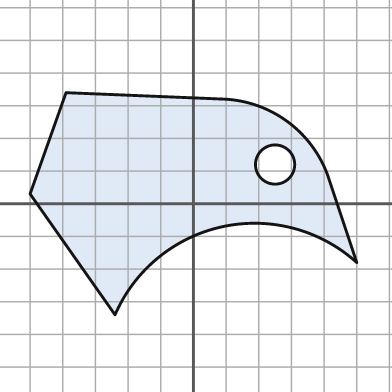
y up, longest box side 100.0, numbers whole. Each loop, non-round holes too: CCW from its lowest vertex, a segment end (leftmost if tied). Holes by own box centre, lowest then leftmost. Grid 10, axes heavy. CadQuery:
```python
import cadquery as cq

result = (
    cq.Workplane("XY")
    .moveTo(-24.0, -34.0)
    .threePointArc((9.0, -7.0), (50.0, -18.0))
    .lineTo(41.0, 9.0)
    .threePointArc((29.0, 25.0), (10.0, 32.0))
    .lineTo(-39.0, 34.0)
    .lineTo(-50.0, 3.0)
    .close()
    .moveTo(25.0, 12.0)
    .circle(6.0)
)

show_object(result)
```